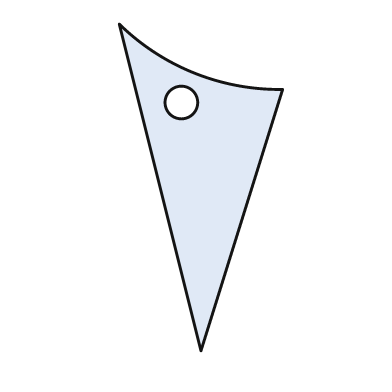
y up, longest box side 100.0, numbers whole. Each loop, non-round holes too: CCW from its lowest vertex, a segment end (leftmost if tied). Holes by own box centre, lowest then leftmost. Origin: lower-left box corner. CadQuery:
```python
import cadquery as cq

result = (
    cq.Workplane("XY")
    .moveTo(25.0, 0.0)
    .lineTo(50.0, 80.0)
    .threePointArc((23.0, 85.0), (0.0, 100.0))
    .close()
    .moveTo(19.0, 76.0)
    .circle(5.0)
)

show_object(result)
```